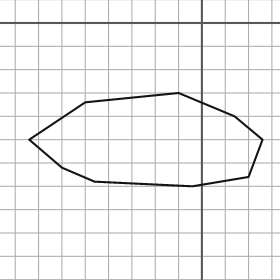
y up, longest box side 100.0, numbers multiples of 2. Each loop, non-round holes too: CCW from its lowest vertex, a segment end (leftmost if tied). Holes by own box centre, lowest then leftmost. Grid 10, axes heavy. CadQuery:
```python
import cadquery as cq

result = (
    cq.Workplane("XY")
    .moveTo(-4.0, -70.0)
    .lineTo(20.0, -66.0)
    .lineTo(26.0, -50.0)
    .lineTo(14.0, -40.0)
    .lineTo(-10.0, -30.0)
    .lineTo(-50.0, -34.0)
    .lineTo(-74.0, -50.0)
    .lineTo(-60.0, -62.0)
    .lineTo(-46.0, -68.0)
    .close()
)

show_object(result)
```